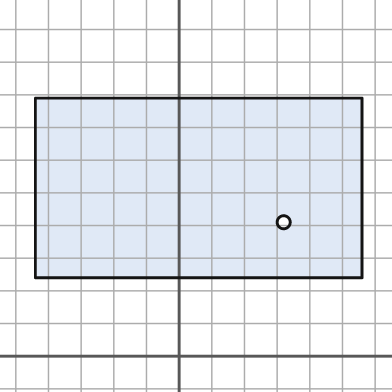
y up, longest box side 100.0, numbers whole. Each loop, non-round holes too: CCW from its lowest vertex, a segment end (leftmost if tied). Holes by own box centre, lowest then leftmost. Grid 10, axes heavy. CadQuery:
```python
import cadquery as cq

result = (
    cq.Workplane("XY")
    .moveTo(-44.0, 24.0)
    .lineTo(56.0, 24.0)
    .lineTo(56.0, 79.0)
    .lineTo(-44.0, 79.0)
    .close()
    .moveTo(32.0, 41.0)
    .circle(2.0)
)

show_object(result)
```